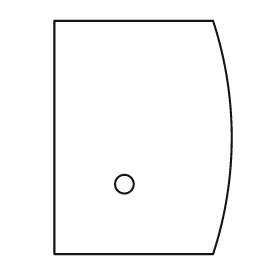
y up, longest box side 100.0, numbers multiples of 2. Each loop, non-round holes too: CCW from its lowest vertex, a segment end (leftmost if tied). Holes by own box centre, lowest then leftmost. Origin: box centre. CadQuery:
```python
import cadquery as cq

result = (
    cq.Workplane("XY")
    .moveTo(-38.0, -50.0)
    .lineTo(30.0, -50.0)
    .threePointArc((38.0, 0.0), (30.0, 50.0))
    .lineTo(-38.0, 50.0)
    .close()
    .moveTo(-8.0, -20.0)
    .circle(4.0)
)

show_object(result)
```